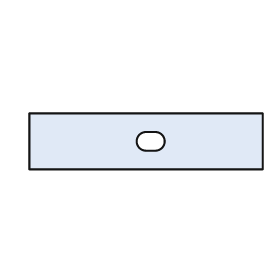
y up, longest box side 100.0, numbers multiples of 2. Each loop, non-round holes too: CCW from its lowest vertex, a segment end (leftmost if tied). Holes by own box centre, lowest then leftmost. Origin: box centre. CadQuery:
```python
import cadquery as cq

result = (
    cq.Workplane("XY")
    .moveTo(-50.0, -12.0)
    .lineTo(50.0, -12.0)
    .lineTo(50.0, 12.0)
    .lineTo(-50.0, 12.0)
    .close()
    .moveTo(0.0, -4.0)
    .lineTo(4.0, -4.0)
    .threePointArc((8.0, 0.0), (4.0, 4.0))
    .lineTo(0.0, 4.0)
    .threePointArc((-4.0, 0.0), (0.0, -4.0))
    .close()
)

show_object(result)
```